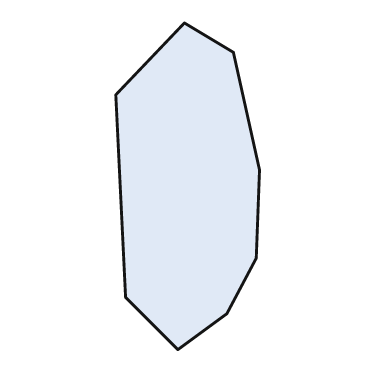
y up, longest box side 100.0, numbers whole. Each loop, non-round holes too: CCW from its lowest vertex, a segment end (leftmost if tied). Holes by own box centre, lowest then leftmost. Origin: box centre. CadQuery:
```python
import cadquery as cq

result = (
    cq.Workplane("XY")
    .moveTo(-3.0, -50.0)
    .lineTo(12.0, -39.0)
    .lineTo(21.0, -22.0)
    .lineTo(22.0, 5.0)
    .lineTo(14.0, 41.0)
    .lineTo(-1.0, 50.0)
    .lineTo(-22.0, 28.0)
    .lineTo(-19.0, -34.0)
    .close()
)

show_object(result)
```